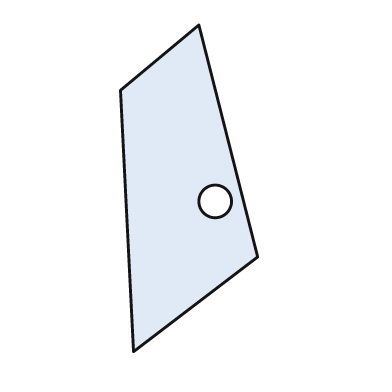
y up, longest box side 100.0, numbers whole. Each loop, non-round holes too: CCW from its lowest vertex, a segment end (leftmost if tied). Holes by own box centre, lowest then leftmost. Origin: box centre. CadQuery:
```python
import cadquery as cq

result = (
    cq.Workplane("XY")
    .moveTo(-17.0, -50.0)
    .lineTo(21.0, -21.0)
    .lineTo(3.0, 50.0)
    .lineTo(-21.0, 30.0)
    .close()
    .moveTo(8.0, -4.0)
    .circle(5.0)
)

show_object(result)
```